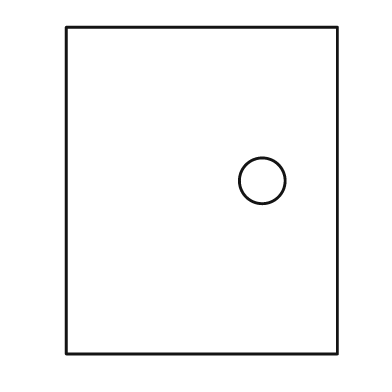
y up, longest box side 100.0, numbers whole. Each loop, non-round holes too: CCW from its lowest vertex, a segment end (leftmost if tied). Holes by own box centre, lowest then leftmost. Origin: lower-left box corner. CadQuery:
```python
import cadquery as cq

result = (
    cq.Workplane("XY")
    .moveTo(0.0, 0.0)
    .lineTo(83.0, 0.0)
    .lineTo(83.0, 100.0)
    .lineTo(0.0, 100.0)
    .close()
    .moveTo(60.0, 53.0)
    .circle(7.0)
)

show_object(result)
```